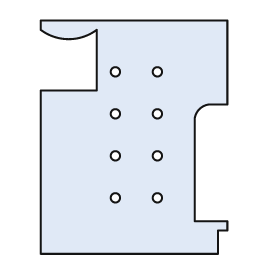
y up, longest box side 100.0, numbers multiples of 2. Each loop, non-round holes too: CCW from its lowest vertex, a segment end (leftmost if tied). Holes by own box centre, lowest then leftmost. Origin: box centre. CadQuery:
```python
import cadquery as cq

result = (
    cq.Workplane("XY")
    .moveTo(-40.0, -50.0)
    .lineTo(36.0, -50.0)
    .lineTo(36.0, -40.0)
    .lineTo(40.0, -40.0)
    .lineTo(40.0, -36.0)
    .lineTo(26.0, -36.0)
    .lineTo(26.0, 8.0)
    .threePointArc((28.0, 12.0), (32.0, 14.0))
    .lineTo(40.0, 14.0)
    .lineTo(40.0, 50.0)
    .lineTo(-40.0, 50.0)
    .lineTo(-40.0, 46.0)
    .threePointArc((-28.0, 42.0), (-16.0, 46.0))
    .lineTo(-16.0, 20.0)
    .lineTo(-40.0, 20.0)
    .close()
    .moveTo(-8.0, -26.0)
    .circle(2.0)
    .moveTo(10.0, -26.0)
    .circle(2.0)
    .moveTo(-8.0, -8.0)
    .circle(2.0)
    .moveTo(10.0, -8.0)
    .circle(2.0)
    .moveTo(-8.0, 10.0)
    .circle(2.0)
    .moveTo(10.0, 10.0)
    .circle(2.0)
    .moveTo(-8.0, 28.0)
    .circle(2.0)
    .moveTo(10.0, 28.0)
    .circle(2.0)
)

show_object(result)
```